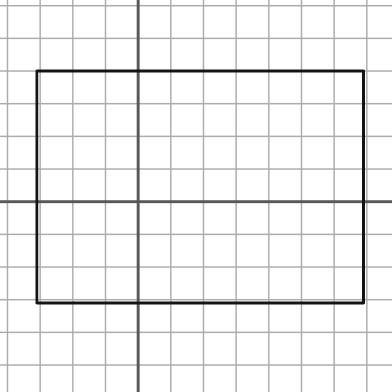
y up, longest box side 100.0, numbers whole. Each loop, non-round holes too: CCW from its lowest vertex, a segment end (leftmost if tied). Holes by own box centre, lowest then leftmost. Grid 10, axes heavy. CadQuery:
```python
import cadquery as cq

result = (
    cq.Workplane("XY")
    .moveTo(-31.0, -31.0)
    .lineTo(69.0, -31.0)
    .lineTo(69.0, 40.0)
    .lineTo(-31.0, 40.0)
    .close()
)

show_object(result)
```